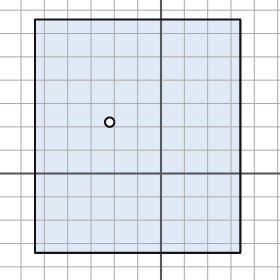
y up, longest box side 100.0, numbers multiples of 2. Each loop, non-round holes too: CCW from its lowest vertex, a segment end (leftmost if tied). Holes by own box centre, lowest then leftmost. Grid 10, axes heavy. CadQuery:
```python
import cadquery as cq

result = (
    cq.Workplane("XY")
    .moveTo(-54.0, -34.0)
    .lineTo(34.0, -34.0)
    .lineTo(34.0, 66.0)
    .lineTo(-54.0, 66.0)
    .close()
    .moveTo(-22.0, 22.0)
    .circle(2.0)
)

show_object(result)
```